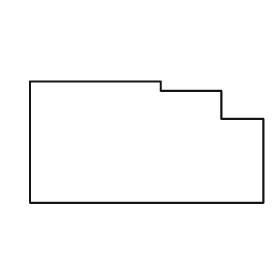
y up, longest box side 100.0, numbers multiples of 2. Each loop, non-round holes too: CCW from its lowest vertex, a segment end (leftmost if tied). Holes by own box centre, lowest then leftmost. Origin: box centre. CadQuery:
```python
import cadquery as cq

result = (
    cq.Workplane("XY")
    .moveTo(-50.0, -26.0)
    .lineTo(50.0, -26.0)
    .lineTo(50.0, 10.0)
    .lineTo(32.0, 10.0)
    .lineTo(32.0, 22.0)
    .lineTo(6.0, 22.0)
    .lineTo(6.0, 26.0)
    .lineTo(-50.0, 26.0)
    .close()
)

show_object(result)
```